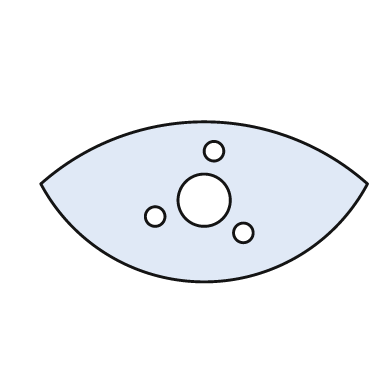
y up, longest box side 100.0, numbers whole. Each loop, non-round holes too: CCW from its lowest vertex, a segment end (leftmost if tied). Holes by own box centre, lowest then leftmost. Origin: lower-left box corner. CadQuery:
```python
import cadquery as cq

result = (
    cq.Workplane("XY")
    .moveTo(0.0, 30.0)
    .threePointArc((50.0, 0.0), (100.0, 30.0))
    .threePointArc((50.0, 49.0), (0.0, 30.0))
    .close()
    .moveTo(62.0, 15.0)
    .circle(3.0)
    .moveTo(35.0, 20.0)
    .circle(3.0)
    .moveTo(50.0, 25.0)
    .circle(8.0)
    .moveTo(53.0, 40.0)
    .circle(3.0)
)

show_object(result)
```